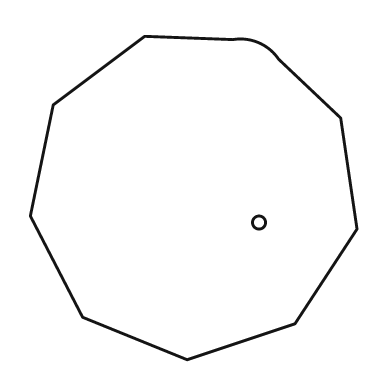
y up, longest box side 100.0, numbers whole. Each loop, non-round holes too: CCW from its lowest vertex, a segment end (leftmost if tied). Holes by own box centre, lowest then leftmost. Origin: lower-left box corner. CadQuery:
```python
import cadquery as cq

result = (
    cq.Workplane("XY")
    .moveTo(48.0, 0.0)
    .lineTo(81.0, 11.0)
    .lineTo(100.0, 40.0)
    .lineTo(95.0, 74.0)
    .lineTo(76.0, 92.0)
    .threePointArc((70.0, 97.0), (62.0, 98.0))
    .lineTo(35.0, 99.0)
    .lineTo(7.0, 78.0)
    .lineTo(0.0, 44.0)
    .lineTo(16.0, 13.0)
    .close()
    .moveTo(70.0, 42.0)
    .circle(2.0)
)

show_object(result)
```